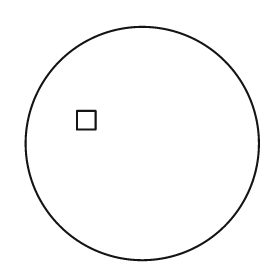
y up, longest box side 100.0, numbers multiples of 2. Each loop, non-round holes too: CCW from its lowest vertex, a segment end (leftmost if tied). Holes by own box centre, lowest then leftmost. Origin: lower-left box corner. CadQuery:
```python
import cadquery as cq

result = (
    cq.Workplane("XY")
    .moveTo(50.0, 50.0)
    .circle(50.0)
    .moveTo(22.0, 56.0)
    .lineTo(30.0, 56.0)
    .lineTo(30.0, 64.0)
    .lineTo(22.0, 64.0)
    .close()
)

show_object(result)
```